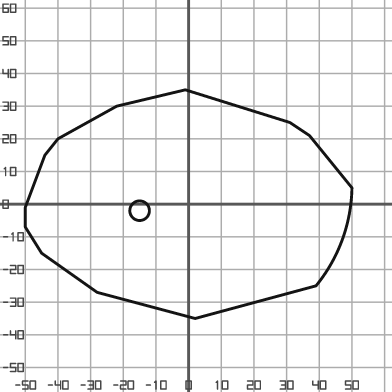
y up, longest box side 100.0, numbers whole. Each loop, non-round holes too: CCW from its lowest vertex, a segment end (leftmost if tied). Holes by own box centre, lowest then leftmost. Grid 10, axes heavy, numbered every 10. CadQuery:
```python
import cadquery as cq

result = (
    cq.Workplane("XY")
    .moveTo(2.0, -35.0)
    .lineTo(39.0, -25.0)
    .threePointArc((47.0, -11.0), (50.0, 5.0))
    .lineTo(37.0, 21.0)
    .lineTo(31.0, 25.0)
    .lineTo(-1.0, 35.0)
    .lineTo(-22.0, 30.0)
    .lineTo(-40.0, 20.0)
    .lineTo(-44.0, 15.0)
    .lineTo(-50.0, -1.0)
    .lineTo(-50.0, -7.0)
    .lineTo(-45.0, -15.0)
    .lineTo(-28.0, -27.0)
    .close()
    .moveTo(-15.0, -2.0)
    .circle(3.0)
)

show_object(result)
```